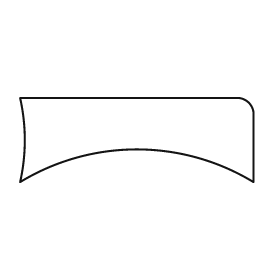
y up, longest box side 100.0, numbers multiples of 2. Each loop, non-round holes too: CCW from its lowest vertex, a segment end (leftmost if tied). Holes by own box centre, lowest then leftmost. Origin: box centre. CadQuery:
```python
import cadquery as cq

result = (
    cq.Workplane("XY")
    .moveTo(-50.0, -18.0)
    .threePointArc((0.0, -4.0), (50.0, -18.0))
    .lineTo(50.0, 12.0)
    .threePointArc((48.0, 16.0), (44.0, 18.0))
    .lineTo(-50.0, 18.0)
    .threePointArc((-48.0, 0.0), (-50.0, -18.0))
    .close()
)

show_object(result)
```